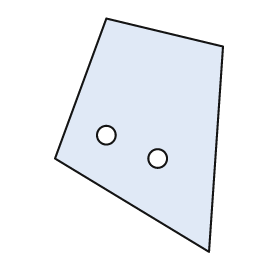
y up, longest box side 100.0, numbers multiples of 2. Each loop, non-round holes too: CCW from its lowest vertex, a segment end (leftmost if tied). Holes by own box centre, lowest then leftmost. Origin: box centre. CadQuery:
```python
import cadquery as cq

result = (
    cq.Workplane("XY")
    .moveTo(30.0, -50.0)
    .lineTo(36.0, 38.0)
    .lineTo(-14.0, 50.0)
    .lineTo(-36.0, -10.0)
    .close()
    .moveTo(8.0, -10.0)
    .circle(4.0)
    .moveTo(-14.0, 0.0)
    .circle(4.0)
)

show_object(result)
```